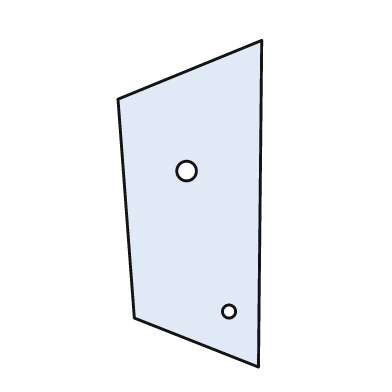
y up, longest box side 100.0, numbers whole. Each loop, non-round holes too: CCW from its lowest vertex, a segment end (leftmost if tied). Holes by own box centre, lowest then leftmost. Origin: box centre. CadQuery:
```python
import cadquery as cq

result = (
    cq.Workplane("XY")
    .moveTo(21.0, -50.0)
    .lineTo(22.0, 50.0)
    .lineTo(-22.0, 32.0)
    .lineTo(-17.0, -35.0)
    .close()
    .moveTo(12.0, -33.0)
    .circle(2.0)
    .moveTo(-1.0, 10.0)
    .circle(3.0)
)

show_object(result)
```